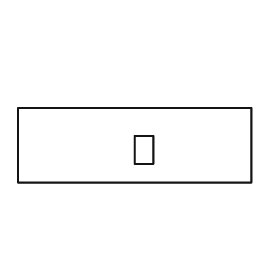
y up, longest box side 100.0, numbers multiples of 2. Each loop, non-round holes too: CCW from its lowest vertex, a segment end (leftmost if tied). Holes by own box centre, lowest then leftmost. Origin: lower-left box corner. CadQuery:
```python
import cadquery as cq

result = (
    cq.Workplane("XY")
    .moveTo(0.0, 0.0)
    .lineTo(100.0, 0.0)
    .lineTo(100.0, 32.0)
    .lineTo(0.0, 32.0)
    .close()
    .moveTo(50.0, 8.0)
    .lineTo(58.0, 8.0)
    .lineTo(58.0, 20.0)
    .lineTo(50.0, 20.0)
    .close()
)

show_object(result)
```